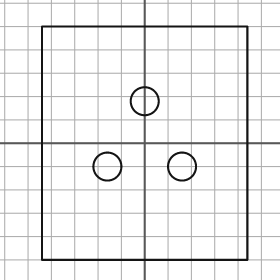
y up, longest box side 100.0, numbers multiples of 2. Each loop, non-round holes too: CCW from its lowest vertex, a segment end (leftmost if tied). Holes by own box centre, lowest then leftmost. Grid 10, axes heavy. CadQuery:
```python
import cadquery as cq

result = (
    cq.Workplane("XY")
    .moveTo(-44.0, -50.0)
    .lineTo(44.0, -50.0)
    .lineTo(44.0, 50.0)
    .lineTo(-44.0, 50.0)
    .close()
    .moveTo(-16.0, -10.0)
    .circle(6.0)
    .moveTo(16.0, -10.0)
    .circle(6.0)
    .moveTo(0.0, 18.0)
    .circle(6.0)
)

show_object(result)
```